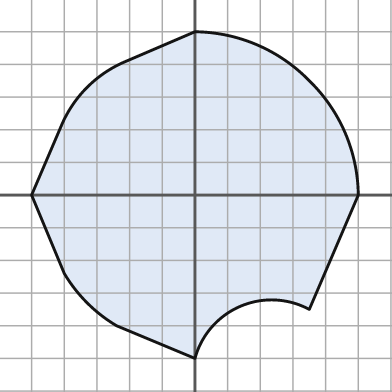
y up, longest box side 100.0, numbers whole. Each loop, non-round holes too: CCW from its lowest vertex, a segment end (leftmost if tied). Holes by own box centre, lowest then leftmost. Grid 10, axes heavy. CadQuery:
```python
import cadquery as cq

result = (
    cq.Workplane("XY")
    .moveTo(0.0, -50.0)
    .threePointArc((14.0, -34.0), (35.0, -35.0))
    .lineTo(50.0, 0.0)
    .threePointArc((46.0, 19.0), (35.0, 35.0))
    .threePointArc((19.0, 46.0), (0.0, 50.0))
    .lineTo(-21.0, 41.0)
    .threePointArc((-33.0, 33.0), (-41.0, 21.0))
    .lineTo(-50.0, 0.0)
    .lineTo(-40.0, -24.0)
    .threePointArc((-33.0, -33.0), (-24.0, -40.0))
    .close()
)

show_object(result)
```